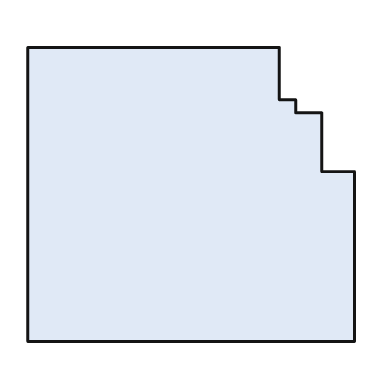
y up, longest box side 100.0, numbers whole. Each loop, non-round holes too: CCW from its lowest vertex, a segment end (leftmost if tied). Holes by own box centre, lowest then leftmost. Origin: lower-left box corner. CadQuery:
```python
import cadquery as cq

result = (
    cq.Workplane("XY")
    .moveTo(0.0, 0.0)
    .lineTo(100.0, 0.0)
    .lineTo(100.0, 52.0)
    .lineTo(90.0, 52.0)
    .lineTo(90.0, 70.0)
    .lineTo(82.0, 70.0)
    .lineTo(82.0, 74.0)
    .lineTo(77.0, 74.0)
    .lineTo(77.0, 90.0)
    .lineTo(0.0, 90.0)
    .close()
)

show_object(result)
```